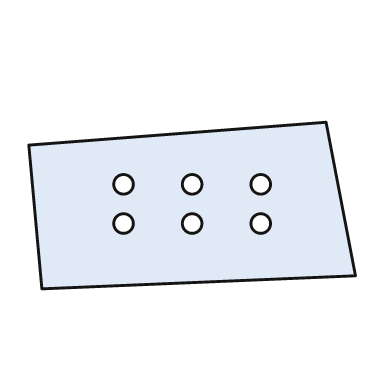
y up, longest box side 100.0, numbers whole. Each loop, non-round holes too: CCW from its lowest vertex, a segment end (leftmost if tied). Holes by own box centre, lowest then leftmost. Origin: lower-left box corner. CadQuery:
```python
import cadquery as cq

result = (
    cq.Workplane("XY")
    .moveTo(4.0, 0.0)
    .lineTo(100.0, 4.0)
    .lineTo(91.0, 51.0)
    .lineTo(0.0, 44.0)
    .close()
    .moveTo(29.0, 20.0)
    .circle(3.0)
    .moveTo(50.0, 20.0)
    .circle(3.0)
    .moveTo(71.0, 20.0)
    .circle(3.0)
    .moveTo(29.0, 32.0)
    .circle(3.0)
    .moveTo(50.0, 32.0)
    .circle(3.0)
    .moveTo(71.0, 32.0)
    .circle(3.0)
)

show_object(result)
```